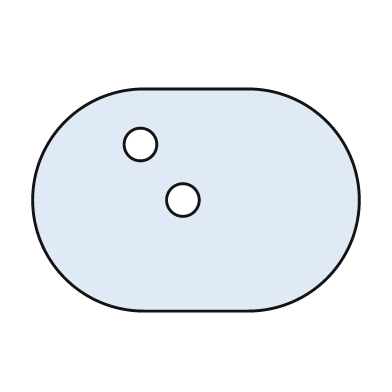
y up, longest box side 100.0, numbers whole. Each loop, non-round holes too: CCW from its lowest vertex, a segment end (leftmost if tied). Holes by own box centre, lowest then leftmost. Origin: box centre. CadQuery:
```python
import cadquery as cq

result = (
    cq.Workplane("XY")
    .moveTo(-16.0, -34.0)
    .lineTo(16.0, -34.0)
    .threePointArc((50.0, 0.0), (16.0, 34.0))
    .lineTo(-16.0, 34.0)
    .threePointArc((-50.0, 0.0), (-16.0, -34.0))
    .close()
    .moveTo(-4.0, 0.0)
    .circle(5.0)
    .moveTo(-17.0, 17.0)
    .circle(5.0)
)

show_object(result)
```